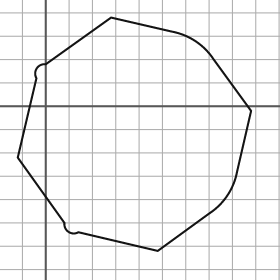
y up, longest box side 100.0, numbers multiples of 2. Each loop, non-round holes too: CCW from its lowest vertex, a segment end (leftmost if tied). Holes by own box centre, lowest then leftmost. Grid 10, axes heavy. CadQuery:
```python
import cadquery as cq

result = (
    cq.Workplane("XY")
    .moveTo(48.0, -62.0)
    .lineTo(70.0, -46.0)
    .threePointArc((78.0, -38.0), (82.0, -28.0))
    .lineTo(88.0, -2.0)
    .lineTo(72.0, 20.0)
    .threePointArc((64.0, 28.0), (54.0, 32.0))
    .lineTo(28.0, 38.0)
    .lineTo(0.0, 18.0)
    .threePointArc((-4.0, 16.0), (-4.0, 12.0))
    .lineTo(-12.0, -22.0)
    .lineTo(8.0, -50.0)
    .threePointArc((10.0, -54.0), (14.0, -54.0))
    .close()
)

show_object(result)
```